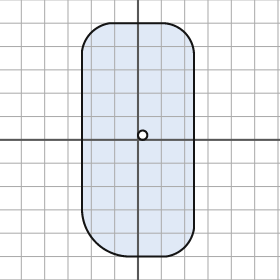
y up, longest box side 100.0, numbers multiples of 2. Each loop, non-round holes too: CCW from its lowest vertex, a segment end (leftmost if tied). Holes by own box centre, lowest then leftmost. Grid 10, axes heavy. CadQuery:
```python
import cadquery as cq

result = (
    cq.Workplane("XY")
    .moveTo(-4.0, -50.0)
    .lineTo(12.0, -50.0)
    .threePointArc((20.0, -46.0), (24.0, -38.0))
    .lineTo(24.0, 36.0)
    .threePointArc((20.0, 46.0), (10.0, 50.0))
    .lineTo(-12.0, 50.0)
    .threePointArc((-20.0, 46.0), (-24.0, 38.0))
    .lineTo(-24.0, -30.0)
    .threePointArc((-18.0, -44.0), (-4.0, -50.0))
    .close()
    .moveTo(2.0, 2.0)
    .circle(2.0)
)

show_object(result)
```